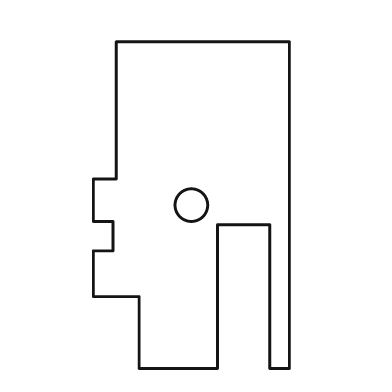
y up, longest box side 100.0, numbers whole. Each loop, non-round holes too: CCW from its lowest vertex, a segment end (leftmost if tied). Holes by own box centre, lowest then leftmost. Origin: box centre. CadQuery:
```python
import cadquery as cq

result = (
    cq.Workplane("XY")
    .moveTo(-16.0, -50.0)
    .lineTo(8.0, -50.0)
    .lineTo(8.0, -6.0)
    .lineTo(24.0, -6.0)
    .lineTo(24.0, -50.0)
    .lineTo(30.0, -50.0)
    .lineTo(30.0, 50.0)
    .lineTo(-23.0, 50.0)
    .lineTo(-23.0, 8.0)
    .lineTo(-30.0, 8.0)
    .lineTo(-30.0, -5.0)
    .lineTo(-24.0, -5.0)
    .lineTo(-24.0, -14.0)
    .lineTo(-30.0, -14.0)
    .lineTo(-30.0, -28.0)
    .lineTo(-16.0, -28.0)
    .close()
    .moveTo(0.0, 0.0)
    .circle(5.0)
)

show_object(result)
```